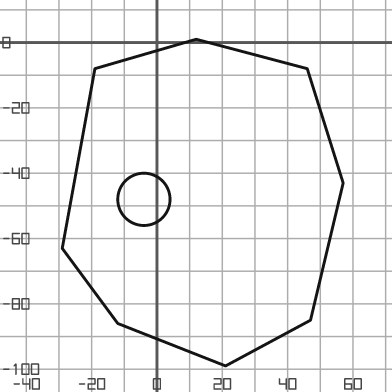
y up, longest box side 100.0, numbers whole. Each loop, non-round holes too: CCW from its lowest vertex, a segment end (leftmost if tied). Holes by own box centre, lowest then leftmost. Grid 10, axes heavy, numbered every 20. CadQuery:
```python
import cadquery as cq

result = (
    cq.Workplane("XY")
    .moveTo(21.0, -99.0)
    .lineTo(47.0, -85.0)
    .lineTo(57.0, -43.0)
    .lineTo(46.0, -8.0)
    .lineTo(12.0, 1.0)
    .lineTo(-19.0, -8.0)
    .lineTo(-29.0, -63.0)
    .lineTo(-12.0, -86.0)
    .close()
    .moveTo(-4.0, -48.0)
    .circle(8.0)
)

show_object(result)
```